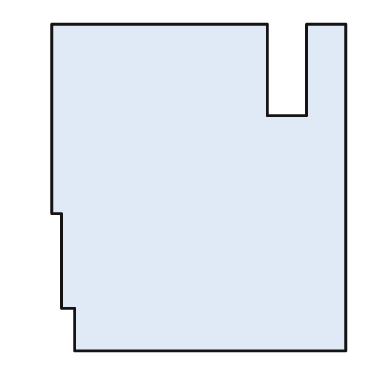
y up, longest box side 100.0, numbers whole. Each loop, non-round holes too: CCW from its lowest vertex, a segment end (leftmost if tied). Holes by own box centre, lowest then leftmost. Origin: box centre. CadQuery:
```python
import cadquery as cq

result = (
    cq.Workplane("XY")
    .moveTo(-38.0, -50.0)
    .lineTo(45.0, -50.0)
    .lineTo(45.0, 50.0)
    .lineTo(33.0, 50.0)
    .lineTo(33.0, 22.0)
    .lineTo(21.0, 22.0)
    .lineTo(21.0, 50.0)
    .lineTo(-45.0, 50.0)
    .lineTo(-45.0, -8.0)
    .lineTo(-42.0, -8.0)
    .lineTo(-42.0, -37.0)
    .lineTo(-38.0, -37.0)
    .close()
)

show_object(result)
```